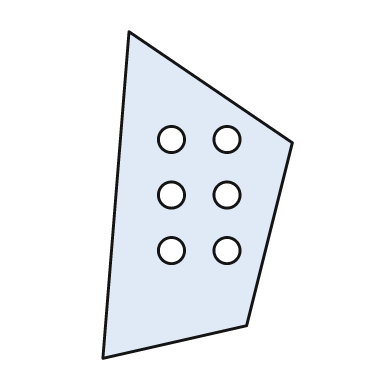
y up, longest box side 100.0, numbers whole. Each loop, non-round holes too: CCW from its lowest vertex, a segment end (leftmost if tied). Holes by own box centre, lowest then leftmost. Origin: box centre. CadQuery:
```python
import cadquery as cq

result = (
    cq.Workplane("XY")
    .moveTo(-29.0, -50.0)
    .lineTo(15.0, -40.0)
    .lineTo(29.0, 16.0)
    .lineTo(-21.0, 50.0)
    .close()
    .moveTo(-8.0, -17.0)
    .circle(4.0)
    .moveTo(9.0, -17.0)
    .circle(4.0)
    .moveTo(-8.0, 0.0)
    .circle(4.0)
    .moveTo(9.0, 0.0)
    .circle(4.0)
    .moveTo(-8.0, 17.0)
    .circle(4.0)
    .moveTo(9.0, 17.0)
    .circle(4.0)
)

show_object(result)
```